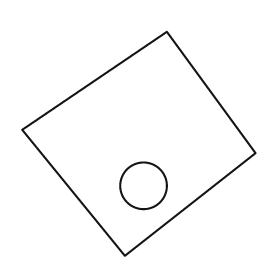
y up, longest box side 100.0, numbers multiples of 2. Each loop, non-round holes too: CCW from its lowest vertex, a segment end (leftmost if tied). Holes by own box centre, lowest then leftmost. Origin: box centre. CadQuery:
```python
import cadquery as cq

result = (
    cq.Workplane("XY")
    .moveTo(-6.0, -48.0)
    .lineTo(50.0, -4.0)
    .lineTo(12.0, 48.0)
    .lineTo(-50.0, 6.0)
    .close()
    .moveTo(2.0, -18.0)
    .circle(10.0)
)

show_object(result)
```